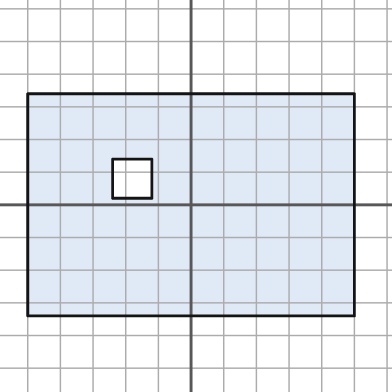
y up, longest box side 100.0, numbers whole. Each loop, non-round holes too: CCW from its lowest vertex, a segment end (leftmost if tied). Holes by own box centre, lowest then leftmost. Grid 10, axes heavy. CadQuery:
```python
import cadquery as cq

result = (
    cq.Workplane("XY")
    .moveTo(-50.0, -34.0)
    .lineTo(50.0, -34.0)
    .lineTo(50.0, 34.0)
    .lineTo(-50.0, 34.0)
    .close()
    .moveTo(-24.0, 2.0)
    .lineTo(-12.0, 2.0)
    .lineTo(-12.0, 14.0)
    .lineTo(-24.0, 14.0)
    .close()
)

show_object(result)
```